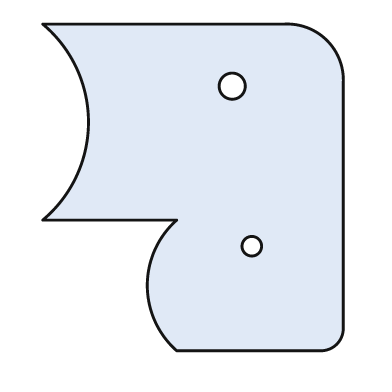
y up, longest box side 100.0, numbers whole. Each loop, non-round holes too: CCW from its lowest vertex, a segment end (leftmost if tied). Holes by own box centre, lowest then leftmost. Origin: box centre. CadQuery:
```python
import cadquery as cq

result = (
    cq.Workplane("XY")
    .moveTo(-5.0, -50.0)
    .lineTo(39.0, -50.0)
    .threePointArc((44.0, -48.0), (46.0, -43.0))
    .lineTo(46.0, 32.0)
    .threePointArc((41.0, 45.0), (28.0, 50.0))
    .lineTo(-46.0, 50.0)
    .threePointArc((-32.0, 20.0), (-46.0, -10.0))
    .lineTo(-5.0, -10.0)
    .threePointArc((-14.0, -30.0), (-5.0, -50.0))
    .close()
    .moveTo(18.0, -18.0)
    .circle(3.0)
    .moveTo(12.0, 31.0)
    .circle(4.0)
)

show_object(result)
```